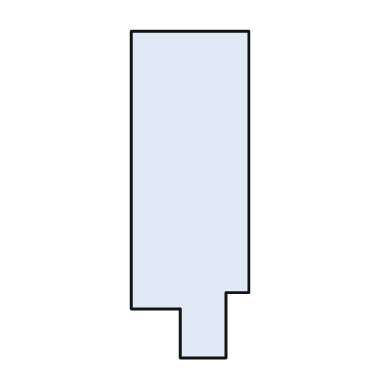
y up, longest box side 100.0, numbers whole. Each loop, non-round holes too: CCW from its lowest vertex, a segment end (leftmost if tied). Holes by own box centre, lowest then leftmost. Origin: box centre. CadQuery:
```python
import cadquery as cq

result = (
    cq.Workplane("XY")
    .moveTo(-3.0, -50.0)
    .lineTo(11.0, -50.0)
    .lineTo(11.0, -30.0)
    .lineTo(18.0, -30.0)
    .lineTo(18.0, 50.0)
    .lineTo(-18.0, 50.0)
    .lineTo(-18.0, -35.0)
    .lineTo(-3.0, -35.0)
    .close()
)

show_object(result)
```